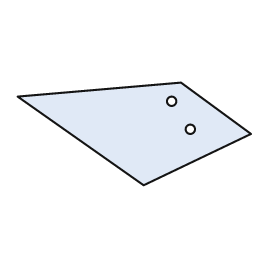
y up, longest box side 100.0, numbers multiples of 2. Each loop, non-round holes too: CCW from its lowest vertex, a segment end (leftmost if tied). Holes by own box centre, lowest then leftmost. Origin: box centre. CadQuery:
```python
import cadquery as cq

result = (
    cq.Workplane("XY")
    .moveTo(4.0, -22.0)
    .lineTo(50.0, 0.0)
    .lineTo(20.0, 22.0)
    .lineTo(-50.0, 16.0)
    .close()
    .moveTo(24.0, 2.0)
    .circle(2.0)
    .moveTo(16.0, 14.0)
    .circle(2.0)
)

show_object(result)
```